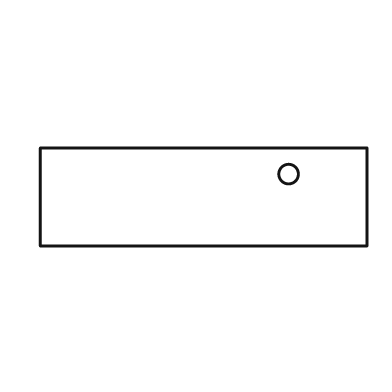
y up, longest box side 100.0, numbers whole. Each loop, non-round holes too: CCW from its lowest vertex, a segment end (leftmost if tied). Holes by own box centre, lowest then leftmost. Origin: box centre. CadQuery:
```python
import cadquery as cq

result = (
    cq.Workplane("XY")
    .moveTo(-50.0, -15.0)
    .lineTo(50.0, -15.0)
    .lineTo(50.0, 15.0)
    .lineTo(-50.0, 15.0)
    .close()
    .moveTo(26.0, 7.0)
    .circle(3.0)
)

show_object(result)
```